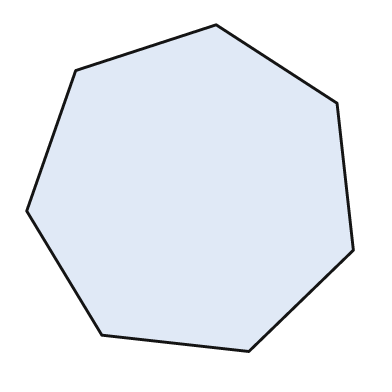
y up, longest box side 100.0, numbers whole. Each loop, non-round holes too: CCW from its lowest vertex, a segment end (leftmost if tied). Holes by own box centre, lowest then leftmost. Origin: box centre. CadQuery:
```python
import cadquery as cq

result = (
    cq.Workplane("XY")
    .moveTo(18.0, -50.0)
    .lineTo(50.0, -19.0)
    .lineTo(45.0, 26.0)
    .lineTo(8.0, 50.0)
    .lineTo(-35.0, 36.0)
    .lineTo(-50.0, -7.0)
    .lineTo(-27.0, -45.0)
    .close()
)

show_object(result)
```